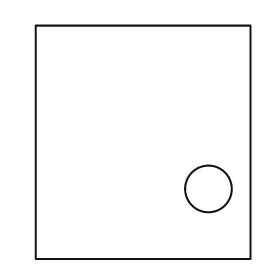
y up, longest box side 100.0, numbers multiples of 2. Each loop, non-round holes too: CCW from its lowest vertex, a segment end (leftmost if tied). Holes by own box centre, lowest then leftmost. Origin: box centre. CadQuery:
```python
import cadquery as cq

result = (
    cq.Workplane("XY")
    .moveTo(-46.0, -50.0)
    .lineTo(46.0, -50.0)
    .lineTo(46.0, 50.0)
    .lineTo(-46.0, 50.0)
    .close()
    .moveTo(28.0, -20.0)
    .circle(10.0)
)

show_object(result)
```